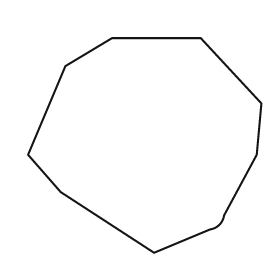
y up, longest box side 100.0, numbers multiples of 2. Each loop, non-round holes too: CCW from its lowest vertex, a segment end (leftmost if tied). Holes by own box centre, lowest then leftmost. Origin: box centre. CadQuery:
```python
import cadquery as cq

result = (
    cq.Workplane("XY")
    .moveTo(4.0, -46.0)
    .lineTo(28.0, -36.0)
    .threePointArc((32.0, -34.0), (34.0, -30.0))
    .lineTo(48.0, -4.0)
    .lineTo(50.0, 18.0)
    .lineTo(24.0, 46.0)
    .lineTo(-14.0, 46.0)
    .lineTo(-34.0, 34.0)
    .lineTo(-50.0, -4.0)
    .lineTo(-36.0, -20.0)
    .close()
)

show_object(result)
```